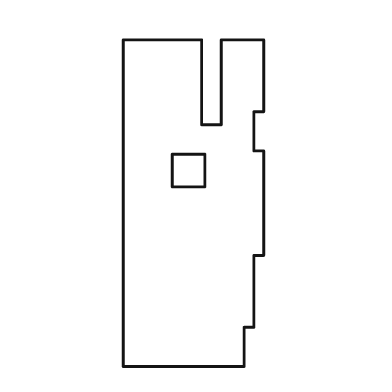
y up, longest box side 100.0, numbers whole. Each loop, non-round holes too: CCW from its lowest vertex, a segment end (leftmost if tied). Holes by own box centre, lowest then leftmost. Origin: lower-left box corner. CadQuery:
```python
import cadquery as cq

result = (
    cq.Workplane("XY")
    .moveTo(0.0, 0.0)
    .lineTo(37.0, 0.0)
    .lineTo(37.0, 12.0)
    .lineTo(40.0, 12.0)
    .lineTo(40.0, 34.0)
    .lineTo(43.0, 34.0)
    .lineTo(43.0, 66.0)
    .lineTo(40.0, 66.0)
    .lineTo(40.0, 78.0)
    .lineTo(43.0, 78.0)
    .lineTo(43.0, 100.0)
    .lineTo(30.0, 100.0)
    .lineTo(30.0, 74.0)
    .lineTo(24.0, 74.0)
    .lineTo(24.0, 100.0)
    .lineTo(0.0, 100.0)
    .close()
    .moveTo(15.0, 55.0)
    .lineTo(25.0, 55.0)
    .lineTo(25.0, 65.0)
    .lineTo(15.0, 65.0)
    .close()
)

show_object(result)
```